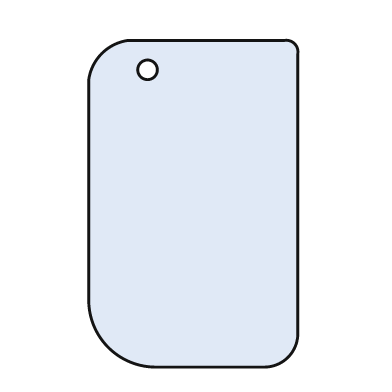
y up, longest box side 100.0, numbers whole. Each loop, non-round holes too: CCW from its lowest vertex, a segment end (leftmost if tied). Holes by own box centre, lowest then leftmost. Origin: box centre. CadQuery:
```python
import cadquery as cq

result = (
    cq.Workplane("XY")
    .moveTo(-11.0, -50.0)
    .lineTo(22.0, -50.0)
    .threePointArc((29.0, -47.0), (32.0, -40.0))
    .lineTo(32.0, 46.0)
    .threePointArc((31.0, 49.0), (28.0, 50.0))
    .lineTo(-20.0, 50.0)
    .threePointArc((-28.0, 46.0), (-32.0, 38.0))
    .lineTo(-32.0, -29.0)
    .threePointArc((-26.0, -44.0), (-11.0, -50.0))
    .close()
    .moveTo(-14.0, 41.0)
    .circle(3.0)
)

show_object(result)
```